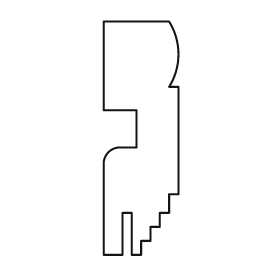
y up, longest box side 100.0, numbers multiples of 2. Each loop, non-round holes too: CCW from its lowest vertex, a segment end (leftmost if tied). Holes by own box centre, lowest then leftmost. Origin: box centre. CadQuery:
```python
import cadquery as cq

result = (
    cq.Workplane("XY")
    .moveTo(-16.0, -50.0)
    .lineTo(-8.0, -50.0)
    .lineTo(-8.0, -32.0)
    .lineTo(-4.0, -32.0)
    .lineTo(-4.0, -50.0)
    .lineTo(0.0, -50.0)
    .lineTo(0.0, -44.0)
    .lineTo(4.0, -44.0)
    .lineTo(4.0, -38.0)
    .lineTo(8.0, -38.0)
    .lineTo(8.0, -32.0)
    .lineTo(12.0, -32.0)
    .lineTo(12.0, -24.0)
    .lineTo(16.0, -24.0)
    .lineTo(16.0, 22.0)
    .lineTo(12.0, 22.0)
    .threePointArc((16.0, 36.0), (12.0, 50.0))
    .lineTo(-16.0, 50.0)
    .lineTo(-16.0, 12.0)
    .lineTo(-2.0, 12.0)
    .lineTo(-2.0, -4.0)
    .lineTo(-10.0, -4.0)
    .threePointArc((-14.0, -6.0), (-16.0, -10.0))
    .close()
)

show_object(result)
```